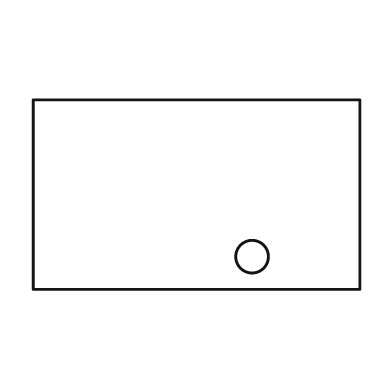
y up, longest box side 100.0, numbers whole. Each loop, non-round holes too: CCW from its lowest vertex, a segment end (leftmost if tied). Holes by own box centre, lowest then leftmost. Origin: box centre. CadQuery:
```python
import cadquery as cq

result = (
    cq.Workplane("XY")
    .moveTo(-50.0, -29.0)
    .lineTo(50.0, -29.0)
    .lineTo(50.0, 29.0)
    .lineTo(-50.0, 29.0)
    .close()
    .moveTo(17.0, -19.0)
    .circle(5.0)
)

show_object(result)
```